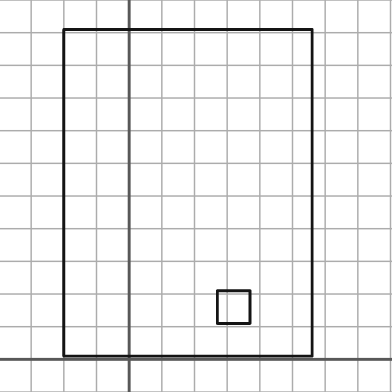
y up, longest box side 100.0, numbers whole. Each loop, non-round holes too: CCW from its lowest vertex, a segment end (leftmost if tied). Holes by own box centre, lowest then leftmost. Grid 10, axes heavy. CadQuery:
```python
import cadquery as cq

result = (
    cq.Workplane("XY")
    .moveTo(-20.0, 1.0)
    .lineTo(56.0, 1.0)
    .lineTo(56.0, 101.0)
    .lineTo(-20.0, 101.0)
    .close()
    .moveTo(27.0, 11.0)
    .lineTo(37.0, 11.0)
    .lineTo(37.0, 21.0)
    .lineTo(27.0, 21.0)
    .close()
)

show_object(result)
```